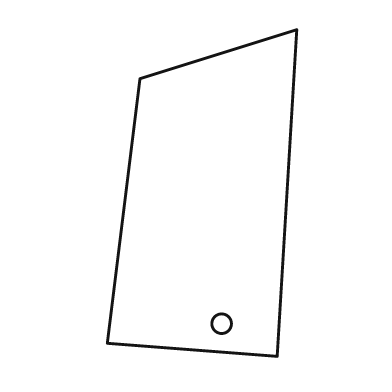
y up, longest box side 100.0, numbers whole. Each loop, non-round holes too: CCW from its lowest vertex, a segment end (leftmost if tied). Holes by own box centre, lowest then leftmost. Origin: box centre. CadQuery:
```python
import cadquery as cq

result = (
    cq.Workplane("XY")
    .moveTo(23.0, -50.0)
    .lineTo(29.0, 50.0)
    .lineTo(-19.0, 35.0)
    .lineTo(-29.0, -46.0)
    .close()
    .moveTo(6.0, -40.0)
    .circle(3.0)
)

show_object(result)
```